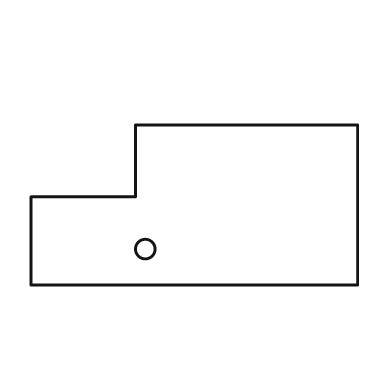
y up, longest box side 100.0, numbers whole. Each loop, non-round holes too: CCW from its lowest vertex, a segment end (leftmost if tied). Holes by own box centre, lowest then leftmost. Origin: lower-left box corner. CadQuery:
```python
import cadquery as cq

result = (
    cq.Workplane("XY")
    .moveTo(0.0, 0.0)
    .lineTo(100.0, 0.0)
    .lineTo(100.0, 49.0)
    .lineTo(32.0, 49.0)
    .lineTo(32.0, 27.0)
    .lineTo(0.0, 27.0)
    .close()
    .moveTo(35.0, 11.0)
    .circle(3.0)
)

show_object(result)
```